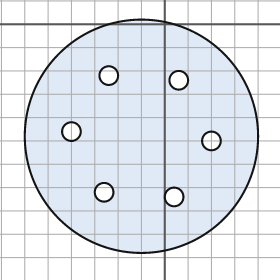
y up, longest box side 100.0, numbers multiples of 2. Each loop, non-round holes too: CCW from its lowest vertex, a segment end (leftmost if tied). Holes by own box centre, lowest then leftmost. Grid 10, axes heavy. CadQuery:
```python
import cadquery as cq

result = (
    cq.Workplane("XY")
    .moveTo(-10.0, -48.0)
    .circle(50.0)
    .moveTo(4.0, -74.0)
    .circle(4.0)
    .moveTo(-26.0, -72.0)
    .circle(4.0)
    .moveTo(20.0, -50.0)
    .circle(4.0)
    .moveTo(-40.0, -46.0)
    .circle(4.0)
    .moveTo(6.0, -24.0)
    .circle(4.0)
    .moveTo(-24.0, -22.0)
    .circle(4.0)
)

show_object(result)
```